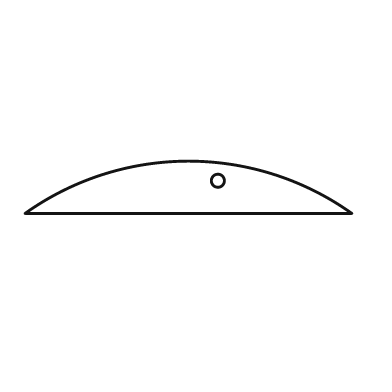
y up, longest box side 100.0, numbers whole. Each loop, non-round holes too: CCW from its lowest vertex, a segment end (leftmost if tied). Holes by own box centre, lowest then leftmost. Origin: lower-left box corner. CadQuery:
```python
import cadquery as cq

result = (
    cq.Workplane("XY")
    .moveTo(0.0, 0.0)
    .lineTo(100.0, 0.0)
    .threePointArc((50.0, 16.0), (0.0, 0.0))
    .close()
    .moveTo(59.0, 10.0)
    .circle(2.0)
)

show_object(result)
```